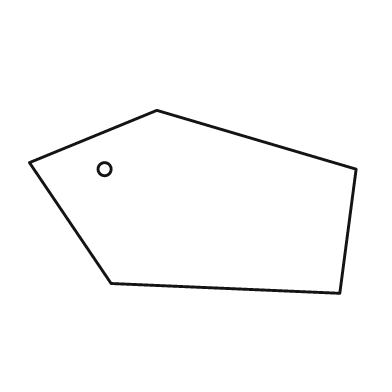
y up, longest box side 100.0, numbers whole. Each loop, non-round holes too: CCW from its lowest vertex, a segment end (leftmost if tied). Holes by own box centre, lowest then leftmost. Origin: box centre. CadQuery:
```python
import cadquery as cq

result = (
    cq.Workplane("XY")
    .moveTo(45.0, -28.0)
    .lineTo(50.0, 10.0)
    .lineTo(-11.0, 28.0)
    .lineTo(-50.0, 12.0)
    .lineTo(-25.0, -25.0)
    .close()
    .moveTo(-27.0, 10.0)
    .circle(2.0)
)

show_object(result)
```